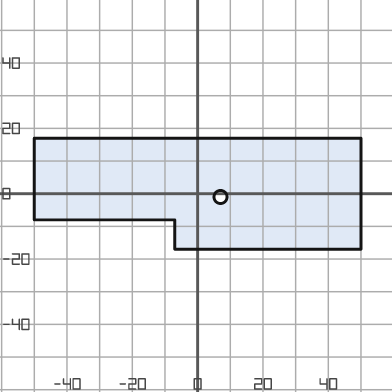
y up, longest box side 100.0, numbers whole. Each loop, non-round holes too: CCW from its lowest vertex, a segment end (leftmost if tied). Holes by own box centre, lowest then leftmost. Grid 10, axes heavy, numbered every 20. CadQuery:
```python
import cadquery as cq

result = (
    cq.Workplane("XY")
    .moveTo(-7.0, -17.0)
    .lineTo(50.0, -17.0)
    .lineTo(50.0, 17.0)
    .lineTo(-50.0, 17.0)
    .lineTo(-50.0, -8.0)
    .lineTo(-7.0, -8.0)
    .close()
    .moveTo(7.0, -1.0)
    .circle(2.0)
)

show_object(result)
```